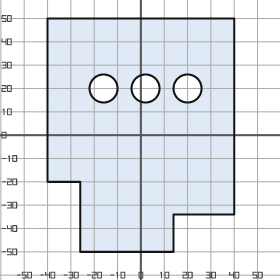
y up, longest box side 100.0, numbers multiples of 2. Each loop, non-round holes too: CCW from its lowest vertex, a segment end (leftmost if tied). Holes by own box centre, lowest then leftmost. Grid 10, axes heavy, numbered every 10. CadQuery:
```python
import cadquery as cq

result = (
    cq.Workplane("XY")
    .moveTo(-26.0, -50.0)
    .lineTo(14.0, -50.0)
    .lineTo(14.0, -34.0)
    .lineTo(40.0, -34.0)
    .lineTo(40.0, 50.0)
    .lineTo(-40.0, 50.0)
    .lineTo(-40.0, -20.0)
    .lineTo(-26.0, -20.0)
    .close()
    .moveTo(-16.0, 20.0)
    .circle(6.0)
    .moveTo(2.0, 20.0)
    .circle(6.0)
    .moveTo(20.0, 20.0)
    .circle(6.0)
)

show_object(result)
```